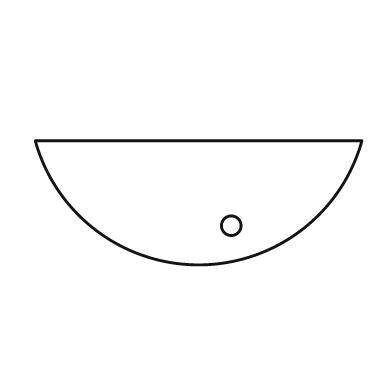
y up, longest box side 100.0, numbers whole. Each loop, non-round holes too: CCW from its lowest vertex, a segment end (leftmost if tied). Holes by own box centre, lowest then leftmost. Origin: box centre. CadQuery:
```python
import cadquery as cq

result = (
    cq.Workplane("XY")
    .moveTo(-50.0, 19.0)
    .threePointArc((0.0, -19.0), (50.0, 19.0))
    .close()
    .moveTo(10.0, -7.0)
    .circle(3.0)
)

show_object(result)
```